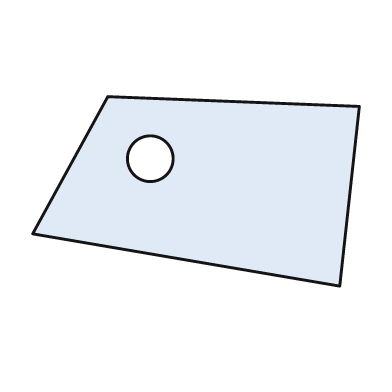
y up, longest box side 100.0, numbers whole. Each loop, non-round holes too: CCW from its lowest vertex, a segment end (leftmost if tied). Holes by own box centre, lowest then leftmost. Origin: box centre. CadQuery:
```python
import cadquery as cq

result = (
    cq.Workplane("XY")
    .moveTo(44.0, -29.0)
    .lineTo(50.0, 26.0)
    .lineTo(-27.0, 29.0)
    .lineTo(-50.0, -13.0)
    .close()
    .moveTo(-14.0, 10.0)
    .circle(7.0)
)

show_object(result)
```